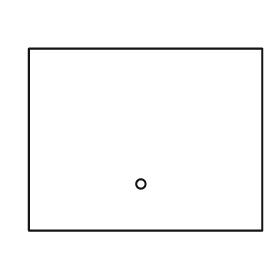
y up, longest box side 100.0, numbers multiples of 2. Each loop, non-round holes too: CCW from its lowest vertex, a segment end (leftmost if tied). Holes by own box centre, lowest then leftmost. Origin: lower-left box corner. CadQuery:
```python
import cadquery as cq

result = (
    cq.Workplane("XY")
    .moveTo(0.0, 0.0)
    .lineTo(100.0, 0.0)
    .lineTo(100.0, 78.0)
    .lineTo(0.0, 78.0)
    .close()
    .moveTo(48.0, 20.0)
    .circle(2.0)
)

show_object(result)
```